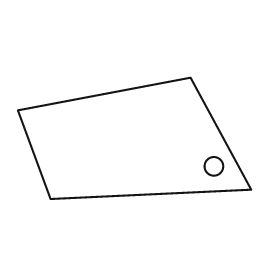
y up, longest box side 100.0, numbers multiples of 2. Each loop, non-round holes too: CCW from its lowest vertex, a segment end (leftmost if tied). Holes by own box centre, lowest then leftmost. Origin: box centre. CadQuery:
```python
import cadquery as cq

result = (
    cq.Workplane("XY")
    .moveTo(-36.0, -26.0)
    .lineTo(50.0, -22.0)
    .lineTo(24.0, 26.0)
    .lineTo(-50.0, 12.0)
    .close()
    .moveTo(34.0, -12.0)
    .circle(4.0)
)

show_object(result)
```